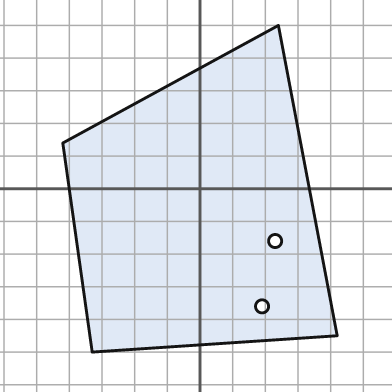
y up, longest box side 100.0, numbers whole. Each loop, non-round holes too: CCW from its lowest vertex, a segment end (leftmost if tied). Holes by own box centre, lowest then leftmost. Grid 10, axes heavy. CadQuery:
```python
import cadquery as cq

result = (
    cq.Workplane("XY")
    .moveTo(-33.0, -50.0)
    .lineTo(42.0, -45.0)
    .lineTo(24.0, 50.0)
    .lineTo(-42.0, 14.0)
    .close()
    .moveTo(19.0, -36.0)
    .circle(2.0)
    .moveTo(23.0, -16.0)
    .circle(2.0)
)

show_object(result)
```